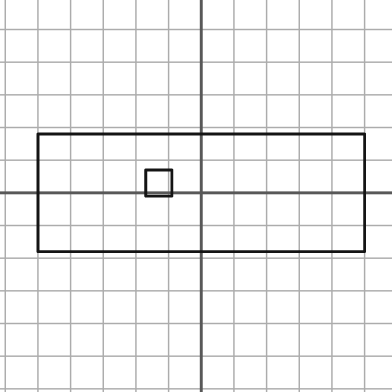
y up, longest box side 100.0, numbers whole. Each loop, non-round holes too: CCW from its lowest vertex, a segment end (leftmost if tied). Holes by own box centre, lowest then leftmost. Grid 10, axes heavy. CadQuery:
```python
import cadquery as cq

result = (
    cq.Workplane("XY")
    .moveTo(-50.0, -18.0)
    .lineTo(50.0, -18.0)
    .lineTo(50.0, 18.0)
    .lineTo(-50.0, 18.0)
    .close()
    .moveTo(-17.0, -1.0)
    .lineTo(-9.0, -1.0)
    .lineTo(-9.0, 7.0)
    .lineTo(-17.0, 7.0)
    .close()
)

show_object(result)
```